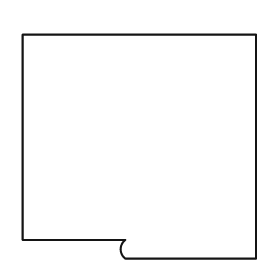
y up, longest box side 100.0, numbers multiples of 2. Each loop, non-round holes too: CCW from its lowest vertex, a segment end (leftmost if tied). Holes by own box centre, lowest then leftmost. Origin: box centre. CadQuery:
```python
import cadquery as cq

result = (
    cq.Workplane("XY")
    .moveTo(-6.0, -48.0)
    .lineTo(50.0, -48.0)
    .lineTo(50.0, 48.0)
    .lineTo(-50.0, 48.0)
    .lineTo(-50.0, -40.0)
    .lineTo(-6.0, -40.0)
    .threePointArc((-8.0, -44.0), (-6.0, -48.0))
    .close()
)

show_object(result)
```